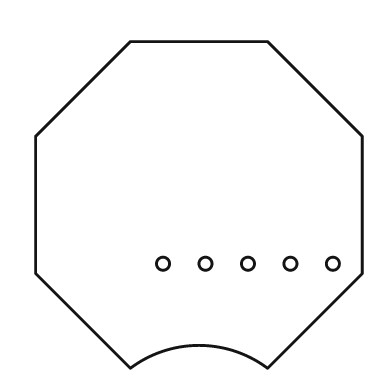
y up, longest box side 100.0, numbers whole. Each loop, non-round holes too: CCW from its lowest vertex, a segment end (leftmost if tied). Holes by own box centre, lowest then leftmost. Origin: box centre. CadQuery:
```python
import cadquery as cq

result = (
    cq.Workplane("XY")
    .moveTo(-21.0, -50.0)
    .threePointArc((0.0, -43.0), (21.0, -50.0))
    .lineTo(50.0, -21.0)
    .lineTo(50.0, 21.0)
    .lineTo(21.0, 50.0)
    .lineTo(-21.0, 50.0)
    .lineTo(-50.0, 21.0)
    .lineTo(-50.0, -21.0)
    .close()
    .moveTo(-11.0, -18.0)
    .circle(2.0)
    .moveTo(2.0, -18.0)
    .circle(2.0)
    .moveTo(15.0, -18.0)
    .circle(2.0)
    .moveTo(28.0, -18.0)
    .circle(2.0)
    .moveTo(41.0, -18.0)
    .circle(2.0)
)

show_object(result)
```